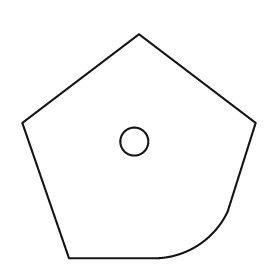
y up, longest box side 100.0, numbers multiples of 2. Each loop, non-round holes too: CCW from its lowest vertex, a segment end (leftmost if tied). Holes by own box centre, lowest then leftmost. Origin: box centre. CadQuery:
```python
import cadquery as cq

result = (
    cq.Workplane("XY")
    .moveTo(-30.0, -48.0)
    .lineTo(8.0, -48.0)
    .threePointArc((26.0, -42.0), (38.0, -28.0))
    .lineTo(50.0, 10.0)
    .lineTo(0.0, 48.0)
    .lineTo(-50.0, 10.0)
    .close()
    .moveTo(-2.0, 2.0)
    .circle(6.0)
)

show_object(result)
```